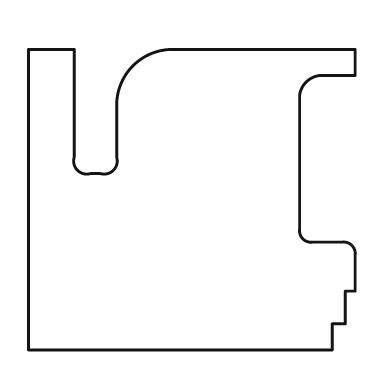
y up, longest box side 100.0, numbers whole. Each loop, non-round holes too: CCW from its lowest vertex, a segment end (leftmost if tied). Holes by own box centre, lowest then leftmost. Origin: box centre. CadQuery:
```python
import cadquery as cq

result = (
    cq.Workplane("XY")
    .moveTo(-50.0, -46.0)
    .lineTo(43.0, -46.0)
    .lineTo(43.0, -38.0)
    .lineTo(47.0, -38.0)
    .lineTo(47.0, -28.0)
    .lineTo(50.0, -28.0)
    .lineTo(50.0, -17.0)
    .threePointArc((49.0, -14.0), (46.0, -13.0))
    .lineTo(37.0, -13.0)
    .threePointArc((34.0, -12.0), (33.0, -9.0))
    .lineTo(33.0, 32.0)
    .threePointArc((35.0, 36.0), (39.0, 38.0))
    .lineTo(50.0, 38.0)
    .lineTo(50.0, 46.0)
    .lineTo(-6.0, 46.0)
    .threePointArc((-18.0, 41.0), (-23.0, 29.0))
    .lineTo(-23.0, 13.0)
    .threePointArc((-24.0, 9.0), (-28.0, 8.0))
    .lineTo(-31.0, 8.0)
    .threePointArc((-35.0, 9.0), (-36.0, 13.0))
    .lineTo(-36.0, 46.0)
    .lineTo(-50.0, 46.0)
    .close()
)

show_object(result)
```